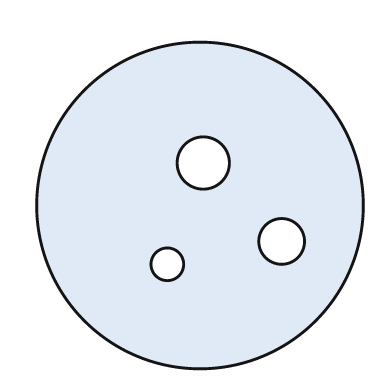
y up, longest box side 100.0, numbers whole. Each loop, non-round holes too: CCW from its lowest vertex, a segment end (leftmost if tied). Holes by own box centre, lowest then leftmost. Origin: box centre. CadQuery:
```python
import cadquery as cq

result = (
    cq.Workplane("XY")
    .moveTo(0.0, 0.0)
    .circle(50.0)
    .moveTo(-10.0, -18.0)
    .circle(5.0)
    .moveTo(25.0, -11.0)
    .circle(7.0)
    .moveTo(1.0, 13.0)
    .circle(8.0)
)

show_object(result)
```